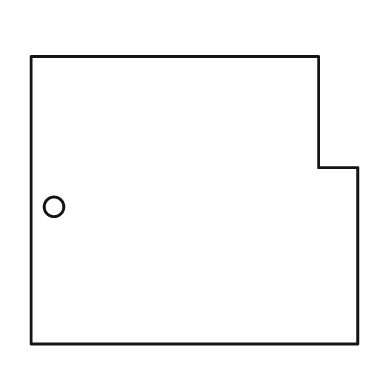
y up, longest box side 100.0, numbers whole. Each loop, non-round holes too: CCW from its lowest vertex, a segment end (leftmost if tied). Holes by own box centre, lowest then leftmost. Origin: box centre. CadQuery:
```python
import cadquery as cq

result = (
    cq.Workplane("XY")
    .moveTo(-50.0, -44.0)
    .lineTo(50.0, -44.0)
    .lineTo(50.0, 10.0)
    .lineTo(38.0, 10.0)
    .lineTo(38.0, 44.0)
    .lineTo(-50.0, 44.0)
    .close()
    .moveTo(-43.0, -2.0)
    .circle(3.0)
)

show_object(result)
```